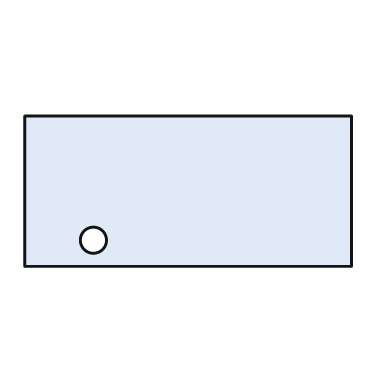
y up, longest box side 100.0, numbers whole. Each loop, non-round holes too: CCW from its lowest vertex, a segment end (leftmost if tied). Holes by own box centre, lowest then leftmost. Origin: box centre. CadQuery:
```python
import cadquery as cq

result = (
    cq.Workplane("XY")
    .moveTo(-50.0, -23.0)
    .lineTo(50.0, -23.0)
    .lineTo(50.0, 23.0)
    .lineTo(-50.0, 23.0)
    .close()
    .moveTo(-29.0, -15.0)
    .circle(4.0)
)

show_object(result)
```